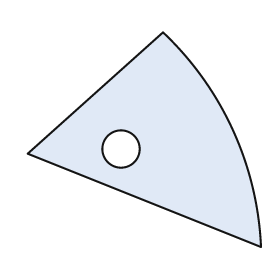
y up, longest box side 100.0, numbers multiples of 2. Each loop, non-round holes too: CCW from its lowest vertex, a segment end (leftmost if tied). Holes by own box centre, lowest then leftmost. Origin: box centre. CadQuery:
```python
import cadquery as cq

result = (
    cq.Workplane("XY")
    .moveTo(50.0, -46.0)
    .threePointArc((38.0, 4.0), (8.0, 46.0))
    .lineTo(-50.0, -6.0)
    .close()
    .moveTo(-10.0, -4.0)
    .circle(8.0)
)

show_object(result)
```